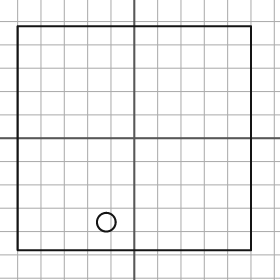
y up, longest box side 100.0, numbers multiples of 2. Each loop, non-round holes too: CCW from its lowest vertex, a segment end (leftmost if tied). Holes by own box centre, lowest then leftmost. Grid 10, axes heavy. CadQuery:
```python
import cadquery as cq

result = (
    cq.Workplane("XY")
    .moveTo(-50.0, -48.0)
    .lineTo(50.0, -48.0)
    .lineTo(50.0, 48.0)
    .lineTo(-50.0, 48.0)
    .close()
    .moveTo(-12.0, -36.0)
    .circle(4.0)
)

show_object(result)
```